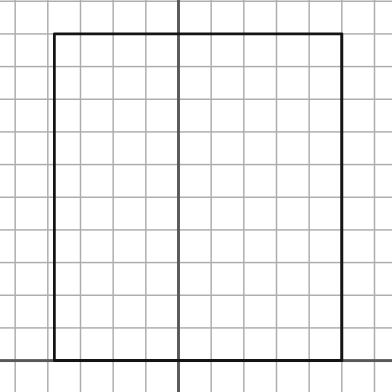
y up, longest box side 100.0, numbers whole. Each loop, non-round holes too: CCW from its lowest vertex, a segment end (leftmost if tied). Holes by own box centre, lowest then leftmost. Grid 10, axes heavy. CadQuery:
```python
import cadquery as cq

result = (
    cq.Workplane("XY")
    .moveTo(-38.0, 0.0)
    .lineTo(50.0, 0.0)
    .lineTo(50.0, 100.0)
    .lineTo(-38.0, 100.0)
    .close()
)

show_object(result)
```